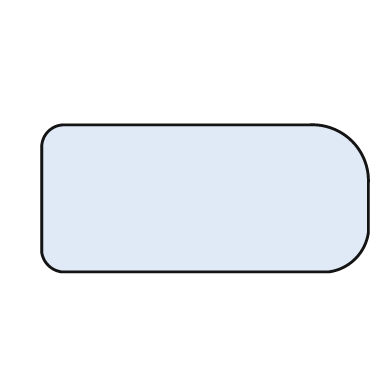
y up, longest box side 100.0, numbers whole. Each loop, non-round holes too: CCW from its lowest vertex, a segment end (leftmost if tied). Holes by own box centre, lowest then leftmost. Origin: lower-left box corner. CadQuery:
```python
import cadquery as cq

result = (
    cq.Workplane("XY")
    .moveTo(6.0, 0.0)
    .lineTo(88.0, 0.0)
    .threePointArc((96.0, 4.0), (100.0, 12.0))
    .lineTo(100.0, 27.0)
    .threePointArc((95.0, 40.0), (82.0, 45.0))
    .lineTo(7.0, 45.0)
    .threePointArc((2.0, 43.0), (0.0, 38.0))
    .lineTo(0.0, 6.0)
    .threePointArc((2.0, 2.0), (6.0, 0.0))
    .close()
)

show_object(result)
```